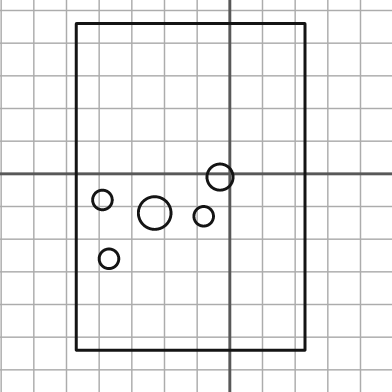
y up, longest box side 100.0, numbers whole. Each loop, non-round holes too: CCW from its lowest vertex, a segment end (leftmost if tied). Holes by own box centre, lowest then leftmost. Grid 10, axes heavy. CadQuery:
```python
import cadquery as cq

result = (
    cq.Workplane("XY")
    .moveTo(-47.0, -54.0)
    .lineTo(23.0, -54.0)
    .lineTo(23.0, 46.0)
    .lineTo(-47.0, 46.0)
    .close()
    .moveTo(-37.0, -26.0)
    .circle(3.0)
    .moveTo(-8.0, -13.0)
    .circle(3.0)
    .moveTo(-23.0, -12.0)
    .circle(5.0)
    .moveTo(-39.0, -8.0)
    .circle(3.0)
    .moveTo(-3.0, -1.0)
    .circle(4.0)
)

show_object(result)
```